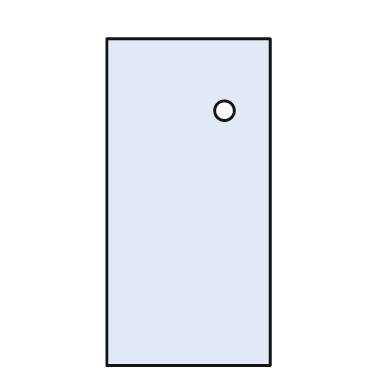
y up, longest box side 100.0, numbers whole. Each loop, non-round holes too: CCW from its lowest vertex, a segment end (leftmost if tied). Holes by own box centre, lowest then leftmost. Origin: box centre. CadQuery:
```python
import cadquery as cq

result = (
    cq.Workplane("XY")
    .moveTo(-25.0, -50.0)
    .lineTo(25.0, -50.0)
    .lineTo(25.0, 50.0)
    .lineTo(-25.0, 50.0)
    .close()
    .moveTo(11.0, 28.0)
    .circle(3.0)
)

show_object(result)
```